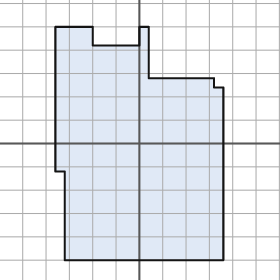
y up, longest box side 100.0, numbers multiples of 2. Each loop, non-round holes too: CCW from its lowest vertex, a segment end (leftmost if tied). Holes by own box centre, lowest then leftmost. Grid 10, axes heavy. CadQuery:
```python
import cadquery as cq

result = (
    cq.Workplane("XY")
    .moveTo(-32.0, -50.0)
    .lineTo(36.0, -50.0)
    .lineTo(36.0, 24.0)
    .lineTo(32.0, 24.0)
    .lineTo(32.0, 28.0)
    .lineTo(4.0, 28.0)
    .lineTo(4.0, 50.0)
    .lineTo(0.0, 50.0)
    .lineTo(0.0, 42.0)
    .lineTo(-20.0, 42.0)
    .lineTo(-20.0, 50.0)
    .lineTo(-36.0, 50.0)
    .lineTo(-36.0, -12.0)
    .lineTo(-32.0, -12.0)
    .close()
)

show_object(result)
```